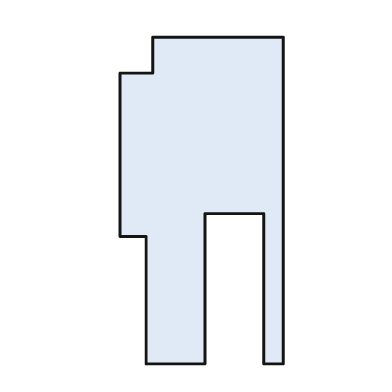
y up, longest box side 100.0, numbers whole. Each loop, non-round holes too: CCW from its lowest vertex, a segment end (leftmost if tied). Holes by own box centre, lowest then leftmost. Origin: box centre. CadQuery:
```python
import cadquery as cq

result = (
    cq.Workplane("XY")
    .moveTo(-17.0, -50.0)
    .lineTo(1.0, -50.0)
    .lineTo(1.0, -4.0)
    .lineTo(19.0, -4.0)
    .lineTo(19.0, -50.0)
    .lineTo(25.0, -50.0)
    .lineTo(25.0, 50.0)
    .lineTo(-15.0, 50.0)
    .lineTo(-15.0, 39.0)
    .lineTo(-25.0, 39.0)
    .lineTo(-25.0, -11.0)
    .lineTo(-17.0, -11.0)
    .close()
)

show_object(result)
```